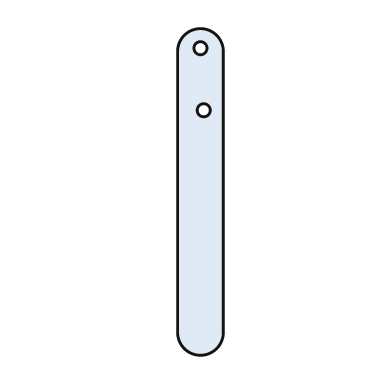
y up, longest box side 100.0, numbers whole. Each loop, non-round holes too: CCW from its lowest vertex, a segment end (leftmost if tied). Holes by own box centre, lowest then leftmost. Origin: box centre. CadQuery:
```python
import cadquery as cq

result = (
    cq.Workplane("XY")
    .moveTo(-7.0, -43.0)
    .threePointArc((0.0, -50.0), (7.0, -43.0))
    .lineTo(7.0, 43.0)
    .threePointArc((0.0, 50.0), (-7.0, 43.0))
    .close()
    .moveTo(1.0, 25.0)
    .circle(2.0)
    .moveTo(0.0, 44.0)
    .circle(2.0)
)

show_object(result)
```